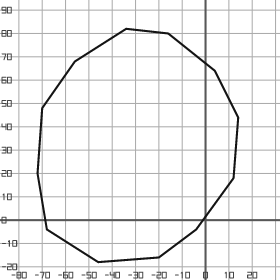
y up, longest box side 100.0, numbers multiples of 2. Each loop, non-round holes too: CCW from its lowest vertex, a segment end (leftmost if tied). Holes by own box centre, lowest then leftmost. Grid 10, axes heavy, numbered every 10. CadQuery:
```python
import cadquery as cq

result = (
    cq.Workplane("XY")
    .moveTo(-46.0, -18.0)
    .lineTo(-20.0, -16.0)
    .lineTo(-4.0, -4.0)
    .lineTo(12.0, 18.0)
    .lineTo(14.0, 44.0)
    .lineTo(4.0, 64.0)
    .lineTo(-16.0, 80.0)
    .lineTo(-34.0, 82.0)
    .lineTo(-56.0, 68.0)
    .lineTo(-70.0, 48.0)
    .lineTo(-72.0, 20.0)
    .lineTo(-68.0, -4.0)
    .close()
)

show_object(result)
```